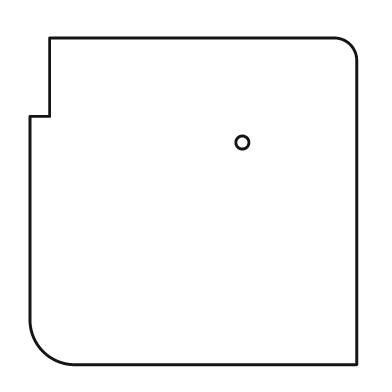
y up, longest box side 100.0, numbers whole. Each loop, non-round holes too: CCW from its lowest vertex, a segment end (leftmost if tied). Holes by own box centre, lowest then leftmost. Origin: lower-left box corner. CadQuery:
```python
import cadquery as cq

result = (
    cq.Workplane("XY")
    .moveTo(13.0, 0.0)
    .lineTo(100.0, 0.0)
    .lineTo(100.0, 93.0)
    .threePointArc((98.0, 98.0), (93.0, 100.0))
    .lineTo(6.0, 100.0)
    .lineTo(6.0, 76.0)
    .lineTo(0.0, 76.0)
    .lineTo(0.0, 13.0)
    .threePointArc((4.0, 4.0), (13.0, 0.0))
    .close()
    .moveTo(65.0, 68.0)
    .circle(2.0)
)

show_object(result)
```